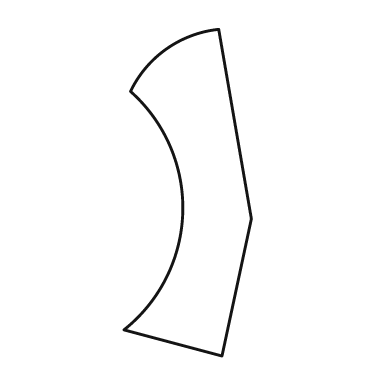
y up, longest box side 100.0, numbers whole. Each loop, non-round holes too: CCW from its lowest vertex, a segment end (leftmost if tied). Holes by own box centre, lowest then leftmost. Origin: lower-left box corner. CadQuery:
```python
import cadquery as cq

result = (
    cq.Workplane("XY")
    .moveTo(30.0, 0.0)
    .lineTo(39.0, 42.0)
    .lineTo(29.0, 100.0)
    .threePointArc((13.0, 94.0), (2.0, 81.0))
    .threePointArc((18.0, 44.0), (0.0, 8.0))
    .close()
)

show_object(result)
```